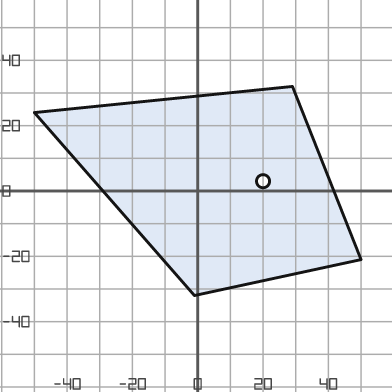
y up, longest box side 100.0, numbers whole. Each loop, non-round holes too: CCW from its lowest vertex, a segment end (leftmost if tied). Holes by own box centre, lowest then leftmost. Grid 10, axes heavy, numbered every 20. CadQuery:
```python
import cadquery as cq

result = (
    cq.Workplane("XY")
    .moveTo(-1.0, -32.0)
    .lineTo(50.0, -21.0)
    .lineTo(29.0, 32.0)
    .lineTo(-50.0, 24.0)
    .close()
    .moveTo(20.0, 3.0)
    .circle(2.0)
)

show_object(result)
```